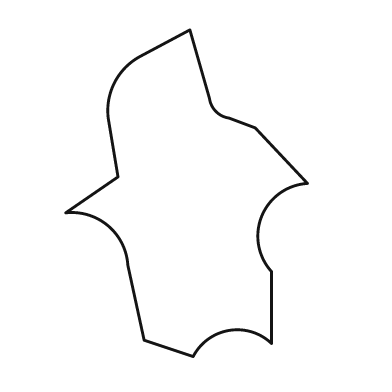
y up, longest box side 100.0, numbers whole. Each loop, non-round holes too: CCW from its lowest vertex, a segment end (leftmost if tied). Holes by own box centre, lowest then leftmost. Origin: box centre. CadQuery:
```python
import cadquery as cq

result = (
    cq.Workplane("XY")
    .moveTo(2.0, -50.0)
    .threePointArc((13.0, -42.0), (26.0, -46.0))
    .lineTo(26.0, -24.0)
    .threePointArc((23.0, -7.0), (37.0, 3.0))
    .lineTo(21.0, 20.0)
    .lineTo(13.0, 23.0)
    .threePointArc((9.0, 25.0), (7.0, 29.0))
    .lineTo(1.0, 50.0)
    .lineTo(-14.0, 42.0)
    .threePointArc((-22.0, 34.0), (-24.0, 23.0))
    .lineTo(-21.0, 5.0)
    .lineTo(-37.0, -6.0)
    .threePointArc((-24.0, -10.0), (-18.0, -22.0))
    .lineTo(-13.0, -45.0)
    .close()
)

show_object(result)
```